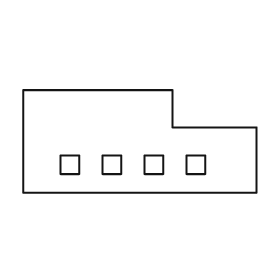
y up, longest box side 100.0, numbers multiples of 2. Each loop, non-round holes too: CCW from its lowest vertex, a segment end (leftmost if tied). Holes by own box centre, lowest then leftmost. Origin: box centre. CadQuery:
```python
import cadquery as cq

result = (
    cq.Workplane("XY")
    .moveTo(-50.0, -22.0)
    .lineTo(50.0, -22.0)
    .lineTo(50.0, 6.0)
    .lineTo(14.0, 6.0)
    .lineTo(14.0, 22.0)
    .lineTo(-50.0, 22.0)
    .close()
    .moveTo(-34.0, -14.0)
    .lineTo(-26.0, -14.0)
    .lineTo(-26.0, -6.0)
    .lineTo(-34.0, -6.0)
    .close()
    .moveTo(-16.0, -14.0)
    .lineTo(-8.0, -14.0)
    .lineTo(-8.0, -6.0)
    .lineTo(-16.0, -6.0)
    .close()
    .moveTo(2.0, -14.0)
    .lineTo(10.0, -14.0)
    .lineTo(10.0, -6.0)
    .lineTo(2.0, -6.0)
    .close()
    .moveTo(20.0, -14.0)
    .lineTo(28.0, -14.0)
    .lineTo(28.0, -6.0)
    .lineTo(20.0, -6.0)
    .close()
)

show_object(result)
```